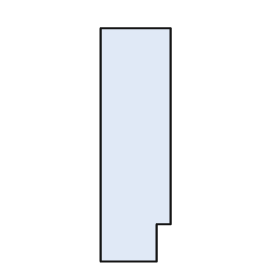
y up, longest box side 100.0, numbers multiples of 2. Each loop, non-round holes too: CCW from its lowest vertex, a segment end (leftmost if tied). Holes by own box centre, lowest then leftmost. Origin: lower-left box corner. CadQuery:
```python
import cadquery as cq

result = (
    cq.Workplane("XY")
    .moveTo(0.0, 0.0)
    .lineTo(24.0, 0.0)
    .lineTo(24.0, 16.0)
    .lineTo(30.0, 16.0)
    .lineTo(30.0, 100.0)
    .lineTo(0.0, 100.0)
    .close()
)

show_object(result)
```